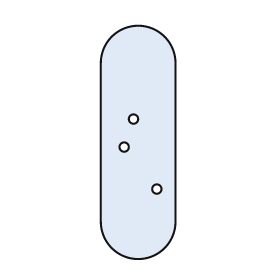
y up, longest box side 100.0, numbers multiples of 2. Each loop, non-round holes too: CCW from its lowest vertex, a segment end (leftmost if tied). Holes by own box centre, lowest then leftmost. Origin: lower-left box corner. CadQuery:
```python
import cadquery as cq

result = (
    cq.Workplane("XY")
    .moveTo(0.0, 16.0)
    .threePointArc((16.0, 0.0), (32.0, 16.0))
    .lineTo(32.0, 84.0)
    .threePointArc((16.0, 100.0), (0.0, 84.0))
    .close()
    .moveTo(24.0, 30.0)
    .circle(2.0)
    .moveTo(10.0, 48.0)
    .circle(2.0)
    .moveTo(14.0, 60.0)
    .circle(2.0)
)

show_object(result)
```